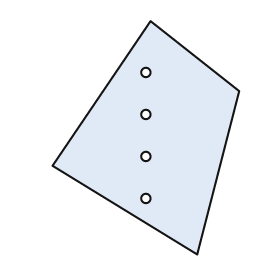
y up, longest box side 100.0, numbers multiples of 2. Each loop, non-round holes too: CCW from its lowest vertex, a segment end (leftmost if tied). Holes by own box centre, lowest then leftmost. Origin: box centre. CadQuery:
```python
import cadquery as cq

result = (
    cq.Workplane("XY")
    .moveTo(22.0, -50.0)
    .lineTo(40.0, 20.0)
    .lineTo(2.0, 50.0)
    .lineTo(-40.0, -12.0)
    .close()
    .moveTo(0.0, -26.0)
    .circle(2.0)
    .moveTo(0.0, -8.0)
    .circle(2.0)
    .moveTo(0.0, 10.0)
    .circle(2.0)
    .moveTo(0.0, 28.0)
    .circle(2.0)
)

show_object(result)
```